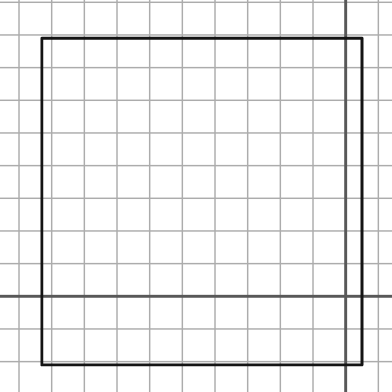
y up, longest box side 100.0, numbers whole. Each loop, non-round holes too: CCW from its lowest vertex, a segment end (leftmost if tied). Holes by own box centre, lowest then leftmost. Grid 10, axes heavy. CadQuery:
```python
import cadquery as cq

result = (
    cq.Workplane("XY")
    .moveTo(-93.0, -21.0)
    .lineTo(5.0, -21.0)
    .lineTo(5.0, 79.0)
    .lineTo(-93.0, 79.0)
    .close()
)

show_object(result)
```